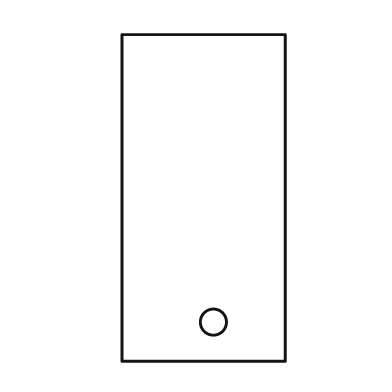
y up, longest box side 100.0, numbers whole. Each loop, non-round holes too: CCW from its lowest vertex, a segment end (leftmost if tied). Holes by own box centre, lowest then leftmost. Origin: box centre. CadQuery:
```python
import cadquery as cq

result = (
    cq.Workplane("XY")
    .moveTo(-25.0, -50.0)
    .lineTo(25.0, -50.0)
    .lineTo(25.0, 50.0)
    .lineTo(-25.0, 50.0)
    .close()
    .moveTo(3.0, -38.0)
    .circle(4.0)
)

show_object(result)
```